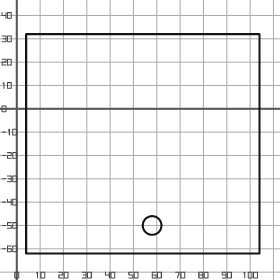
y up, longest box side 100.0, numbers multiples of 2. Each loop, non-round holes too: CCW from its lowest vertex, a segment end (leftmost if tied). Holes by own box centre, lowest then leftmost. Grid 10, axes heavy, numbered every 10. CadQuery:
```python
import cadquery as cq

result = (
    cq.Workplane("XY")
    .moveTo(4.0, -62.0)
    .lineTo(104.0, -62.0)
    .lineTo(104.0, 32.0)
    .lineTo(4.0, 32.0)
    .close()
    .moveTo(58.0, -50.0)
    .circle(4.0)
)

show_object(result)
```